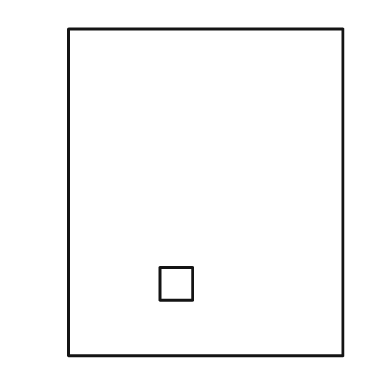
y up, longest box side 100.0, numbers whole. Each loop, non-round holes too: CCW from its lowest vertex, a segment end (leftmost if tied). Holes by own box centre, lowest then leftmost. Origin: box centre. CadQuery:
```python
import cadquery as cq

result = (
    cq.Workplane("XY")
    .moveTo(-42.0, -50.0)
    .lineTo(42.0, -50.0)
    .lineTo(42.0, 50.0)
    .lineTo(-42.0, 50.0)
    .close()
    .moveTo(-14.0, -33.0)
    .lineTo(-4.0, -33.0)
    .lineTo(-4.0, -23.0)
    .lineTo(-14.0, -23.0)
    .close()
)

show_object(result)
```